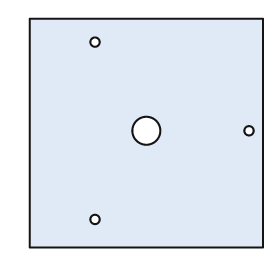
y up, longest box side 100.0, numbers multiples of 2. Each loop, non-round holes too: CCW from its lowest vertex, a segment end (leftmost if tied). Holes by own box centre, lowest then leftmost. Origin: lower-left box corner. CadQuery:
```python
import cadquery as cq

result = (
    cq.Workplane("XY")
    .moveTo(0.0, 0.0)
    .lineTo(100.0, 0.0)
    .lineTo(100.0, 98.0)
    .lineTo(0.0, 98.0)
    .close()
    .moveTo(28.0, 12.0)
    .circle(2.0)
    .moveTo(50.0, 50.0)
    .circle(6.0)
    .moveTo(94.0, 50.0)
    .circle(2.0)
    .moveTo(28.0, 88.0)
    .circle(2.0)
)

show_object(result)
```